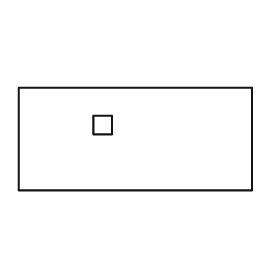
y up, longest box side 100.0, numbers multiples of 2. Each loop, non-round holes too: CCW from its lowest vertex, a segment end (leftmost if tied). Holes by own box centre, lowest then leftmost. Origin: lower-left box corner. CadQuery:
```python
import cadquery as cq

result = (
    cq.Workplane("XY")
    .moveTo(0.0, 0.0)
    .lineTo(100.0, 0.0)
    .lineTo(100.0, 44.0)
    .lineTo(0.0, 44.0)
    .close()
    .moveTo(32.0, 24.0)
    .lineTo(40.0, 24.0)
    .lineTo(40.0, 32.0)
    .lineTo(32.0, 32.0)
    .close()
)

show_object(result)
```